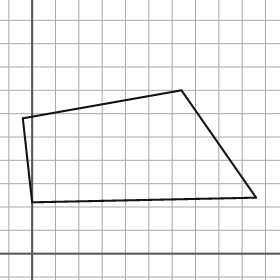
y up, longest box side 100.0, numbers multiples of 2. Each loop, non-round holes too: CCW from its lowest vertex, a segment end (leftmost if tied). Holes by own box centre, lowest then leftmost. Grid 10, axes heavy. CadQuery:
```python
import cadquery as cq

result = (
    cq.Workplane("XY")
    .moveTo(0.0, 22.0)
    .lineTo(96.0, 24.0)
    .lineTo(64.0, 70.0)
    .lineTo(-4.0, 58.0)
    .close()
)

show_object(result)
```